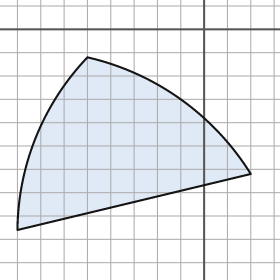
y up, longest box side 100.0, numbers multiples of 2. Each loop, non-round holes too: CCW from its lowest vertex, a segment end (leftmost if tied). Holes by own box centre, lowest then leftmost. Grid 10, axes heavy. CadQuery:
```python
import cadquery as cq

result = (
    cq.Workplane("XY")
    .moveTo(-80.0, -86.0)
    .lineTo(20.0, -62.0)
    .threePointArc((-10.0, -30.0), (-50.0, -12.0))
    .threePointArc((-72.0, -46.0), (-80.0, -86.0))
    .close()
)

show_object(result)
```